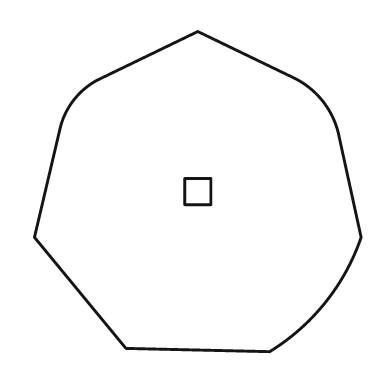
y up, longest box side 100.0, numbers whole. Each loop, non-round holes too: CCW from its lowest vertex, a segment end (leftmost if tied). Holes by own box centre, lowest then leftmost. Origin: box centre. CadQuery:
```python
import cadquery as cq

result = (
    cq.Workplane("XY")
    .moveTo(22.0, -49.0)
    .threePointArc((39.0, -34.0), (50.0, -14.0))
    .lineTo(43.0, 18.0)
    .threePointArc((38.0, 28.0), (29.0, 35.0))
    .lineTo(0.0, 49.0)
    .lineTo(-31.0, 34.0)
    .threePointArc((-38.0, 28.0), (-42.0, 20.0))
    .lineTo(-50.0, -14.0)
    .lineTo(-22.0, -48.0)
    .close()
    .moveTo(-4.0, -4.0)
    .lineTo(4.0, -4.0)
    .lineTo(4.0, 4.0)
    .lineTo(-4.0, 4.0)
    .close()
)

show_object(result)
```